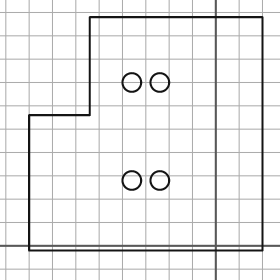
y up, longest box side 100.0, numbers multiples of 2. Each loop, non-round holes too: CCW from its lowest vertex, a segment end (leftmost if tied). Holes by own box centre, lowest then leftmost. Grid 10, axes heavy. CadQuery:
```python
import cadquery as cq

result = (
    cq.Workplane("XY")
    .moveTo(-80.0, -2.0)
    .lineTo(20.0, -2.0)
    .lineTo(20.0, 98.0)
    .lineTo(-54.0, 98.0)
    .lineTo(-54.0, 56.0)
    .lineTo(-80.0, 56.0)
    .close()
    .moveTo(-36.0, 28.0)
    .circle(4.0)
    .moveTo(-24.0, 28.0)
    .circle(4.0)
    .moveTo(-36.0, 70.0)
    .circle(4.0)
    .moveTo(-24.0, 70.0)
    .circle(4.0)
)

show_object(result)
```